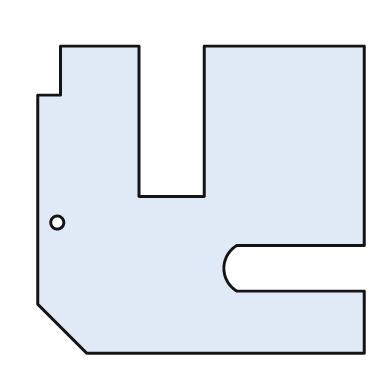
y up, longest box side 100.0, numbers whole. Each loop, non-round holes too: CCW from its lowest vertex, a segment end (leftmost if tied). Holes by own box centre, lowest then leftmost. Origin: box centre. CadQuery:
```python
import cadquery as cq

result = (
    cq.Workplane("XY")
    .moveTo(-35.0, -47.0)
    .lineTo(50.0, -47.0)
    .lineTo(50.0, -28.0)
    .lineTo(11.0, -28.0)
    .threePointArc((7.0, -21.0), (11.0, -14.0))
    .lineTo(50.0, -14.0)
    .lineTo(50.0, 47.0)
    .lineTo(1.0, 47.0)
    .lineTo(1.0, 1.0)
    .lineTo(-19.0, 1.0)
    .lineTo(-19.0, 47.0)
    .lineTo(-43.0, 47.0)
    .lineTo(-43.0, 32.0)
    .lineTo(-50.0, 32.0)
    .lineTo(-50.0, -32.0)
    .close()
    .moveTo(-44.0, -7.0)
    .circle(2.0)
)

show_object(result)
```